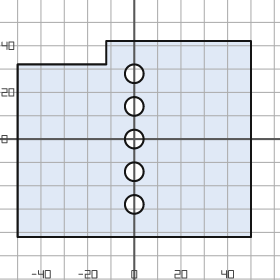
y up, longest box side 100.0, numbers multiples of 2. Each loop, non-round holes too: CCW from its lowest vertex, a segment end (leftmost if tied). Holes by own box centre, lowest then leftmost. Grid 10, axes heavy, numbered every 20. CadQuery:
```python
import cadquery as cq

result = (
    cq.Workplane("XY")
    .moveTo(-50.0, -42.0)
    .lineTo(50.0, -42.0)
    .lineTo(50.0, 42.0)
    .lineTo(-12.0, 42.0)
    .lineTo(-12.0, 32.0)
    .lineTo(-50.0, 32.0)
    .close()
    .moveTo(0.0, -28.0)
    .circle(4.0)
    .moveTo(0.0, -14.0)
    .circle(4.0)
    .moveTo(0.0, 0.0)
    .circle(4.0)
    .moveTo(0.0, 14.0)
    .circle(4.0)
    .moveTo(0.0, 28.0)
    .circle(4.0)
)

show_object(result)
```